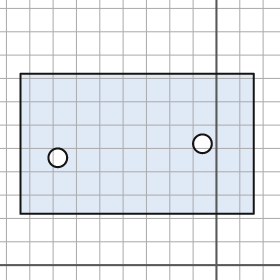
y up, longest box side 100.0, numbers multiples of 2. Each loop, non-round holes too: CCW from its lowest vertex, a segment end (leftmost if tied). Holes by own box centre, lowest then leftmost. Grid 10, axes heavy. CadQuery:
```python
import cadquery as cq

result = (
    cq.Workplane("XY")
    .moveTo(-84.0, 22.0)
    .lineTo(16.0, 22.0)
    .lineTo(16.0, 82.0)
    .lineTo(-84.0, 82.0)
    .close()
    .moveTo(-68.0, 46.0)
    .circle(4.0)
    .moveTo(-6.0, 52.0)
    .circle(4.0)
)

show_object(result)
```